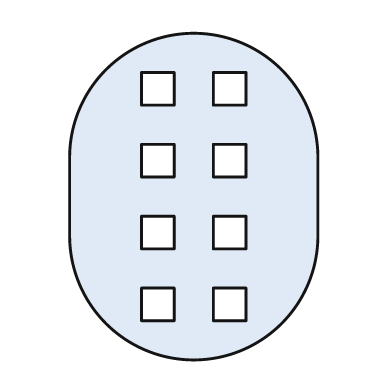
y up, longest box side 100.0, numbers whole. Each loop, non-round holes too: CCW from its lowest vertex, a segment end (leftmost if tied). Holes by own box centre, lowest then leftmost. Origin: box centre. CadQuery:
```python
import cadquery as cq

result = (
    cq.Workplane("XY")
    .moveTo(-38.0, -12.0)
    .threePointArc((0.0, -50.0), (38.0, -12.0))
    .lineTo(38.0, 12.0)
    .threePointArc((0.0, 50.0), (-38.0, 12.0))
    .close()
    .moveTo(-16.0, -38.0)
    .lineTo(-6.0, -38.0)
    .lineTo(-6.0, -28.0)
    .lineTo(-16.0, -28.0)
    .close()
    .moveTo(6.0, -38.0)
    .lineTo(16.0, -38.0)
    .lineTo(16.0, -28.0)
    .lineTo(6.0, -28.0)
    .close()
    .moveTo(-16.0, -16.0)
    .lineTo(-6.0, -16.0)
    .lineTo(-6.0, -6.0)
    .lineTo(-16.0, -6.0)
    .close()
    .moveTo(6.0, -16.0)
    .lineTo(16.0, -16.0)
    .lineTo(16.0, -6.0)
    .lineTo(6.0, -6.0)
    .close()
    .moveTo(-16.0, 6.0)
    .lineTo(-6.0, 6.0)
    .lineTo(-6.0, 16.0)
    .lineTo(-16.0, 16.0)
    .close()
    .moveTo(6.0, 6.0)
    .lineTo(16.0, 6.0)
    .lineTo(16.0, 16.0)
    .lineTo(6.0, 16.0)
    .close()
    .moveTo(-16.0, 28.0)
    .lineTo(-6.0, 28.0)
    .lineTo(-6.0, 38.0)
    .lineTo(-16.0, 38.0)
    .close()
    .moveTo(6.0, 28.0)
    .lineTo(16.0, 28.0)
    .lineTo(16.0, 38.0)
    .lineTo(6.0, 38.0)
    .close()
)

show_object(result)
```